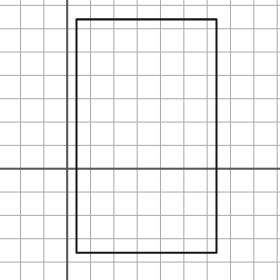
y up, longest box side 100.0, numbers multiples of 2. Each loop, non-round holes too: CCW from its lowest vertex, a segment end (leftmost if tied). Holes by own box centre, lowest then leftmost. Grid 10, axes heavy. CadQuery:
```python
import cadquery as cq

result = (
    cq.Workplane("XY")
    .moveTo(4.0, -36.0)
    .lineTo(64.0, -36.0)
    .lineTo(64.0, 64.0)
    .lineTo(4.0, 64.0)
    .close()
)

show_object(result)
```